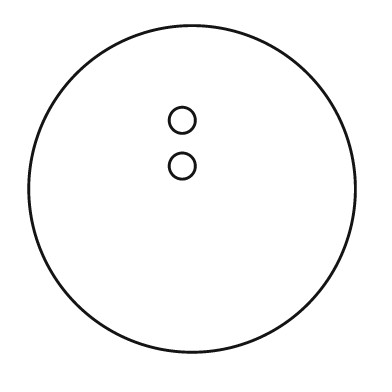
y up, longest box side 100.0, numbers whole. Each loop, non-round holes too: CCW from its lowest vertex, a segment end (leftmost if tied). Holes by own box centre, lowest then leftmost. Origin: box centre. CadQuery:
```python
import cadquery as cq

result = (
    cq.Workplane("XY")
    .moveTo(0.0, 0.0)
    .circle(50.0)
    .moveTo(-3.0, 7.0)
    .circle(4.0)
    .moveTo(-3.0, 21.0)
    .circle(4.0)
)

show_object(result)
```